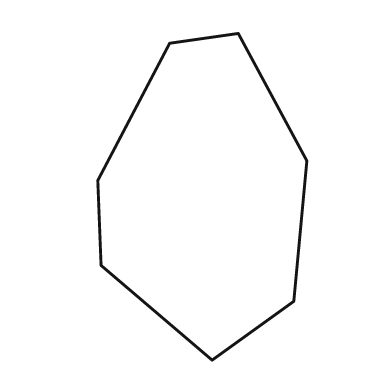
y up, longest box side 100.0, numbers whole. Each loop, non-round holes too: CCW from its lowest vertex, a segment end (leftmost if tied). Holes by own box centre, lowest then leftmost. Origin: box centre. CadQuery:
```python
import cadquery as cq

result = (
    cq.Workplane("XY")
    .moveTo(3.0, -50.0)
    .lineTo(28.0, -32.0)
    .lineTo(32.0, 11.0)
    .lineTo(11.0, 50.0)
    .lineTo(-10.0, 47.0)
    .lineTo(-32.0, 5.0)
    .lineTo(-31.0, -21.0)
    .close()
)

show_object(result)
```